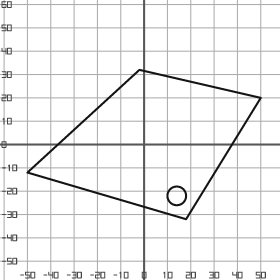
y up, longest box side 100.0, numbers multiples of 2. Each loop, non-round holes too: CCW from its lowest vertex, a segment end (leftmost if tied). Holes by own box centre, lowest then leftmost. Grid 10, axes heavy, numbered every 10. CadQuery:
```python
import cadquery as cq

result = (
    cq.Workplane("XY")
    .moveTo(18.0, -32.0)
    .lineTo(50.0, 20.0)
    .lineTo(-2.0, 32.0)
    .lineTo(-50.0, -12.0)
    .close()
    .moveTo(14.0, -22.0)
    .circle(4.0)
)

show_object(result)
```